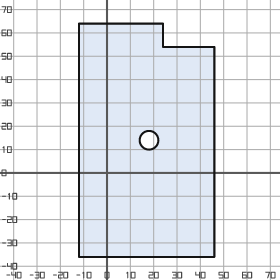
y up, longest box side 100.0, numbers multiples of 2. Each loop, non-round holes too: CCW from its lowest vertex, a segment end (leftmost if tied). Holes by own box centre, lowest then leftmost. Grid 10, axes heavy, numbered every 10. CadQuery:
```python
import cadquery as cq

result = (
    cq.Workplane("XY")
    .moveTo(-12.0, -36.0)
    .lineTo(46.0, -36.0)
    .lineTo(46.0, 54.0)
    .lineTo(24.0, 54.0)
    .lineTo(24.0, 64.0)
    .lineTo(-12.0, 64.0)
    .close()
    .moveTo(18.0, 14.0)
    .circle(4.0)
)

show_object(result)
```